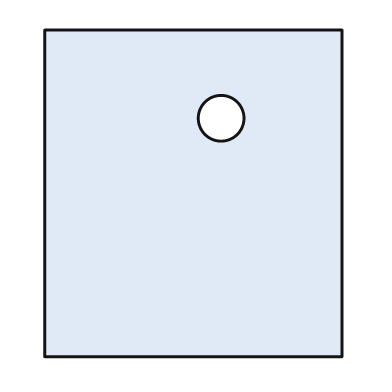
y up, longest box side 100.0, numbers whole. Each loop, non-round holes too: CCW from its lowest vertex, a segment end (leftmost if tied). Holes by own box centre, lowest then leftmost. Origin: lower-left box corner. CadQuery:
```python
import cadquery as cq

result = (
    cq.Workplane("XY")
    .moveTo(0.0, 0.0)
    .lineTo(91.0, 0.0)
    .lineTo(91.0, 100.0)
    .lineTo(0.0, 100.0)
    .close()
    .moveTo(54.0, 73.0)
    .circle(7.0)
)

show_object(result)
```